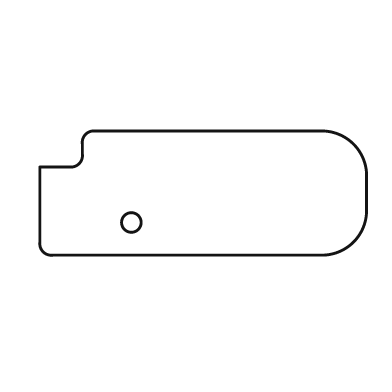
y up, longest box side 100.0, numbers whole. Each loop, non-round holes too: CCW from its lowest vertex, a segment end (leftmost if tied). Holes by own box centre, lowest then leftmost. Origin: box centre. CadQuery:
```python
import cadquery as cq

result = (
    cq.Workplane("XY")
    .moveTo(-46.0, -19.0)
    .lineTo(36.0, -19.0)
    .threePointArc((46.0, -15.0), (50.0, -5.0))
    .lineTo(50.0, 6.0)
    .threePointArc((46.0, 15.0), (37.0, 19.0))
    .lineTo(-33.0, 19.0)
    .threePointArc((-36.0, 18.0), (-37.0, 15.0))
    .lineTo(-37.0, 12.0)
    .threePointArc((-38.0, 9.0), (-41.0, 8.0))
    .lineTo(-50.0, 8.0)
    .lineTo(-50.0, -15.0)
    .threePointArc((-49.0, -18.0), (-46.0, -19.0))
    .close()
    .moveTo(-22.0, -9.0)
    .circle(3.0)
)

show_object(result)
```